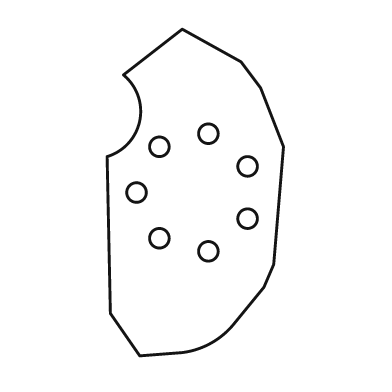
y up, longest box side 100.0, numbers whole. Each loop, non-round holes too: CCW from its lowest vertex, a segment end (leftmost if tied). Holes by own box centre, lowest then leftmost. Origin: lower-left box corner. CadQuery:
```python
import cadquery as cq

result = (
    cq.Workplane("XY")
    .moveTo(10.0, 0.0)
    .lineTo(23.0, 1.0)
    .threePointArc((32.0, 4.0), (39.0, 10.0))
    .lineTo(48.0, 21.0)
    .lineTo(51.0, 28.0)
    .lineTo(54.0, 64.0)
    .lineTo(47.0, 82.0)
    .lineTo(41.0, 90.0)
    .lineTo(23.0, 100.0)
    .lineTo(5.0, 86.0)
    .threePointArc((10.0, 72.0), (0.0, 61.0))
    .lineTo(1.0, 13.0)
    .close()
    .moveTo(31.0, 32.0)
    .circle(3.0)
    .moveTo(16.0, 36.0)
    .circle(3.0)
    .moveTo(43.0, 42.0)
    .circle(3.0)
    .moveTo(9.0, 50.0)
    .circle(3.0)
    .moveTo(43.0, 58.0)
    .circle(3.0)
    .moveTo(16.0, 64.0)
    .circle(3.0)
    .moveTo(31.0, 68.0)
    .circle(3.0)
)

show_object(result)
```